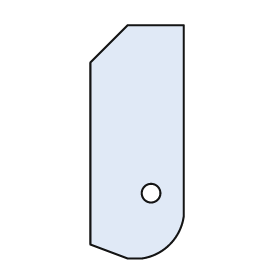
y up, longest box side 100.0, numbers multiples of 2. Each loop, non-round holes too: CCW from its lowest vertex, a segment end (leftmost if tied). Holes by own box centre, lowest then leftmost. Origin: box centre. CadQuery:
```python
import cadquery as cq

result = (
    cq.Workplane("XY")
    .moveTo(-4.0, -50.0)
    .lineTo(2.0, -50.0)
    .threePointArc((14.0, -44.0), (20.0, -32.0))
    .lineTo(20.0, 50.0)
    .lineTo(-4.0, 50.0)
    .lineTo(-20.0, 34.0)
    .lineTo(-20.0, -44.0)
    .close()
    .moveTo(6.0, -22.0)
    .circle(4.0)
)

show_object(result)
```